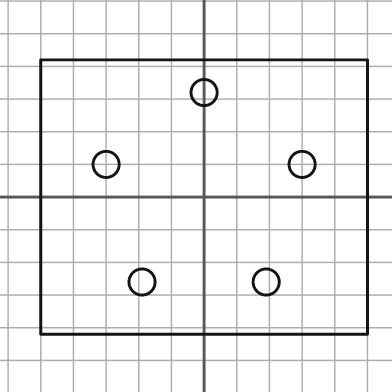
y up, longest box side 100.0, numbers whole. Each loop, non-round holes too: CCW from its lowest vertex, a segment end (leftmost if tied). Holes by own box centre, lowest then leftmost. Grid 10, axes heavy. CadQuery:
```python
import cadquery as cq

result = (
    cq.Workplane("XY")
    .moveTo(-50.0, -42.0)
    .lineTo(50.0, -42.0)
    .lineTo(50.0, 42.0)
    .lineTo(-50.0, 42.0)
    .close()
    .moveTo(-19.0, -26.0)
    .circle(4.0)
    .moveTo(19.0, -26.0)
    .circle(4.0)
    .moveTo(-30.0, 10.0)
    .circle(4.0)
    .moveTo(30.0, 10.0)
    .circle(4.0)
    .moveTo(0.0, 32.0)
    .circle(4.0)
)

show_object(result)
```